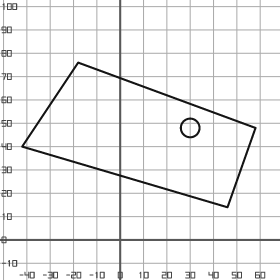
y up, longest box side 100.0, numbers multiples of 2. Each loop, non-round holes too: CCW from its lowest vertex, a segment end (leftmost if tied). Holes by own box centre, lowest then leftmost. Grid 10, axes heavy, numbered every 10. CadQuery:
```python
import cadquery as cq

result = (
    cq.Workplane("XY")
    .moveTo(46.0, 14.0)
    .lineTo(58.0, 48.0)
    .lineTo(-18.0, 76.0)
    .lineTo(-42.0, 40.0)
    .close()
    .moveTo(30.0, 48.0)
    .circle(4.0)
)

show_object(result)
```